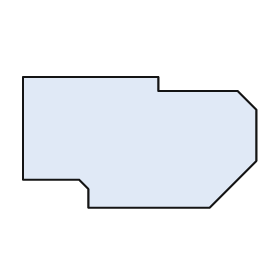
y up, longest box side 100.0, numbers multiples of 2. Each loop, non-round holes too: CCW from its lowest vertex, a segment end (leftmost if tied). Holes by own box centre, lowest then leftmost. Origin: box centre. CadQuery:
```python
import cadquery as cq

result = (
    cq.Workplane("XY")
    .moveTo(-22.0, -28.0)
    .lineTo(30.0, -28.0)
    .lineTo(50.0, -8.0)
    .lineTo(50.0, 14.0)
    .lineTo(42.0, 22.0)
    .lineTo(8.0, 22.0)
    .lineTo(8.0, 28.0)
    .lineTo(-50.0, 28.0)
    .lineTo(-50.0, -16.0)
    .lineTo(-26.0, -16.0)
    .lineTo(-22.0, -20.0)
    .close()
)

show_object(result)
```